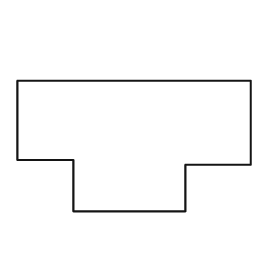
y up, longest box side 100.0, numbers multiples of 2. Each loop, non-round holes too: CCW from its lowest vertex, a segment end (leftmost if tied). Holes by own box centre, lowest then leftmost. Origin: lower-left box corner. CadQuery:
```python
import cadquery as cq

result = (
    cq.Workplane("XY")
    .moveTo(24.0, 0.0)
    .lineTo(72.0, 0.0)
    .lineTo(72.0, 20.0)
    .lineTo(100.0, 20.0)
    .lineTo(100.0, 56.0)
    .lineTo(0.0, 56.0)
    .lineTo(0.0, 22.0)
    .lineTo(24.0, 22.0)
    .close()
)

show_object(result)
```